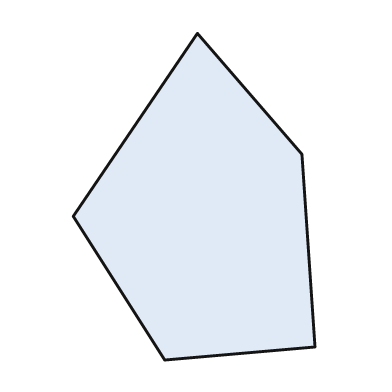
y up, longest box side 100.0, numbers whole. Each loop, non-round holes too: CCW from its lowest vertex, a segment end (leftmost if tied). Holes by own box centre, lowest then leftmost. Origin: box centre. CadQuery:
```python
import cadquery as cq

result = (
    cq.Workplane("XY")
    .moveTo(-9.0, -50.0)
    .lineTo(37.0, -46.0)
    .lineTo(33.0, 13.0)
    .lineTo(1.0, 50.0)
    .lineTo(-37.0, -6.0)
    .close()
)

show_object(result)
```